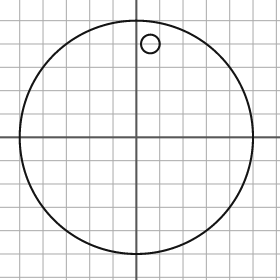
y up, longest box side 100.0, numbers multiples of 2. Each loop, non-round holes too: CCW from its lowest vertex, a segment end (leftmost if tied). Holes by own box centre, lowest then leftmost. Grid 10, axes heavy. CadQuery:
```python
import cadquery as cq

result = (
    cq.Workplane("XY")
    .moveTo(0.0, 0.0)
    .circle(50.0)
    .moveTo(6.0, 40.0)
    .circle(4.0)
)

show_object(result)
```